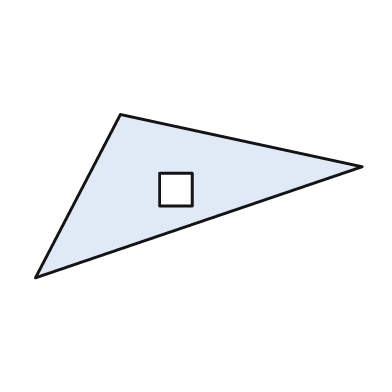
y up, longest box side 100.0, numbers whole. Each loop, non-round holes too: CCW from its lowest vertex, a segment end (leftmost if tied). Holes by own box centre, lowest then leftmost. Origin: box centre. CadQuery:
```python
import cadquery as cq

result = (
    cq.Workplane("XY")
    .moveTo(-50.0, -25.0)
    .lineTo(50.0, 9.0)
    .lineTo(-24.0, 25.0)
    .close()
    .moveTo(-12.0, -3.0)
    .lineTo(-2.0, -3.0)
    .lineTo(-2.0, 7.0)
    .lineTo(-12.0, 7.0)
    .close()
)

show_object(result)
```